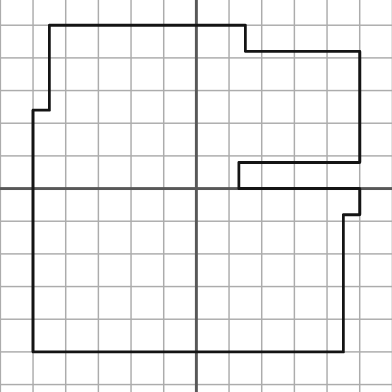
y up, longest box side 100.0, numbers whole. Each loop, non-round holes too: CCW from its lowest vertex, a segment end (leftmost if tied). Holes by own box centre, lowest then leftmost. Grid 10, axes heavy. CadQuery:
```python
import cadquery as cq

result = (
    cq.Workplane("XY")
    .moveTo(-50.0, -50.0)
    .lineTo(45.0, -50.0)
    .lineTo(45.0, -8.0)
    .lineTo(50.0, -8.0)
    .lineTo(50.0, 0.0)
    .lineTo(13.0, 0.0)
    .lineTo(13.0, 8.0)
    .lineTo(50.0, 8.0)
    .lineTo(50.0, 42.0)
    .lineTo(15.0, 42.0)
    .lineTo(15.0, 50.0)
    .lineTo(-45.0, 50.0)
    .lineTo(-45.0, 24.0)
    .lineTo(-50.0, 24.0)
    .close()
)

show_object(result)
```